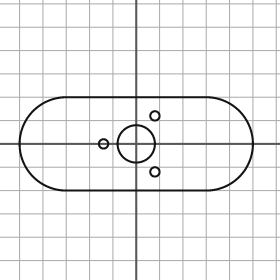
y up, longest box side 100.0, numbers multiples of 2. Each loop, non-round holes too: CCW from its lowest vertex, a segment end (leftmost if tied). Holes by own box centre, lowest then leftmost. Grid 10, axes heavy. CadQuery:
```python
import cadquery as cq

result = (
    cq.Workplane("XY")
    .moveTo(-30.0, -20.0)
    .lineTo(30.0, -20.0)
    .threePointArc((50.0, 0.0), (30.0, 20.0))
    .lineTo(-30.0, 20.0)
    .threePointArc((-50.0, 0.0), (-30.0, -20.0))
    .close()
    .moveTo(8.0, -12.0)
    .circle(2.0)
    .moveTo(-14.0, 0.0)
    .circle(2.0)
    .moveTo(0.0, 0.0)
    .circle(8.0)
    .moveTo(8.0, 12.0)
    .circle(2.0)
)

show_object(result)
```